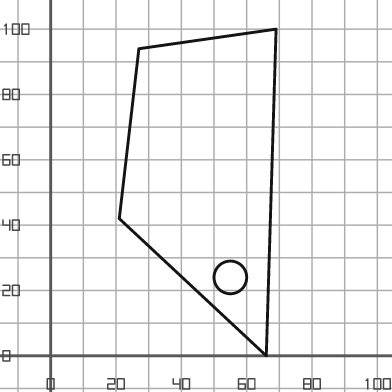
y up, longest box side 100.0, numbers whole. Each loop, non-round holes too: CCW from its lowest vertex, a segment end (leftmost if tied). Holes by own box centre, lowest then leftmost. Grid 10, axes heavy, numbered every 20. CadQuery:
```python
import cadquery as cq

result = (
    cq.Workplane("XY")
    .moveTo(66.0, 0.0)
    .lineTo(69.0, 100.0)
    .lineTo(27.0, 94.0)
    .lineTo(21.0, 42.0)
    .close()
    .moveTo(55.0, 24.0)
    .circle(5.0)
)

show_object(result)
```